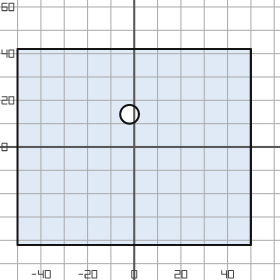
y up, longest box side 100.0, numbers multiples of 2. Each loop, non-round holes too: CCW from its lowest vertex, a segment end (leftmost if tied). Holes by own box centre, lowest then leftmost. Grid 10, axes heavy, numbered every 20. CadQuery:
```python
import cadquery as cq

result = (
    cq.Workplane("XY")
    .moveTo(-50.0, -42.0)
    .lineTo(50.0, -42.0)
    .lineTo(50.0, 42.0)
    .lineTo(-50.0, 42.0)
    .close()
    .moveTo(-2.0, 14.0)
    .circle(4.0)
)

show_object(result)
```